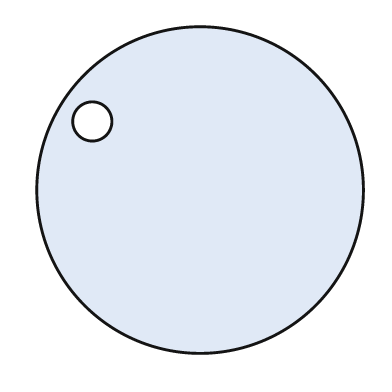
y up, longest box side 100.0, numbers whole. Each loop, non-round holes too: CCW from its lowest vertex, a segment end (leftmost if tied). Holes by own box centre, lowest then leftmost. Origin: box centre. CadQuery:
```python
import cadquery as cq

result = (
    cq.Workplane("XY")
    .moveTo(0.0, 0.0)
    .circle(50.0)
    .moveTo(-33.0, 21.0)
    .circle(6.0)
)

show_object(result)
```